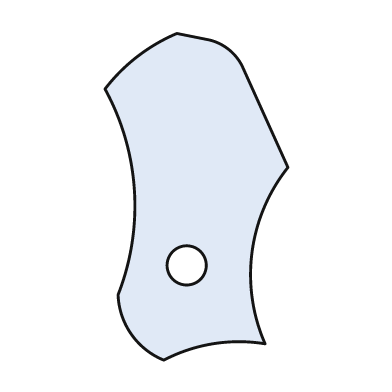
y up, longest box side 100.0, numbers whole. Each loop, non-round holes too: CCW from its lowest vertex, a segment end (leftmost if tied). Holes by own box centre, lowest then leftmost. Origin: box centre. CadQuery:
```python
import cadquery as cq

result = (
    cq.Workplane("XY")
    .moveTo(-10.0, -50.0)
    .threePointArc((5.0, -45.0), (21.0, -45.0))
    .threePointArc((17.0, -17.0), (28.0, 9.0))
    .lineTo(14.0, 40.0)
    .threePointArc((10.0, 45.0), (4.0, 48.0))
    .lineTo(-6.0, 50.0)
    .threePointArc((-18.0, 43.0), (-28.0, 33.0))
    .threePointArc((-19.0, 2.0), (-24.0, -30.0))
    .threePointArc((-20.0, -42.0), (-10.0, -50.0))
    .close()
    .moveTo(-3.0, -21.0)
    .circle(6.0)
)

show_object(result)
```